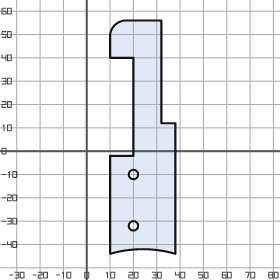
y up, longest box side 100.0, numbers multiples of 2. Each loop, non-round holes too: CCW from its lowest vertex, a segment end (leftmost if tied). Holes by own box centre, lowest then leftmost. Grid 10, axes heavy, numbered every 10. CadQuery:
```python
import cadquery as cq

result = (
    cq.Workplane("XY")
    .moveTo(10.0, -44.0)
    .threePointArc((24.0, -42.0), (38.0, -44.0))
    .lineTo(38.0, 12.0)
    .lineTo(32.0, 12.0)
    .lineTo(32.0, 56.0)
    .lineTo(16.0, 56.0)
    .threePointArc((12.0, 54.0), (10.0, 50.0))
    .lineTo(10.0, 40.0)
    .lineTo(20.0, 40.0)
    .lineTo(20.0, -2.0)
    .lineTo(10.0, -2.0)
    .close()
    .moveTo(20.0, -32.0)
    .circle(2.0)
    .moveTo(20.0, -10.0)
    .circle(2.0)
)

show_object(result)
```